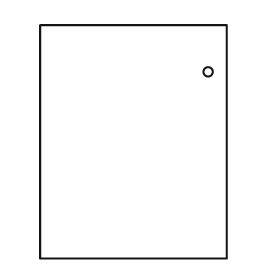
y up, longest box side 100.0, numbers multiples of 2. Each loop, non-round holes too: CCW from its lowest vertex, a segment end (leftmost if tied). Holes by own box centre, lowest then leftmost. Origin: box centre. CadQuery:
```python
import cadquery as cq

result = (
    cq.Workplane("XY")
    .moveTo(-40.0, -50.0)
    .lineTo(40.0, -50.0)
    .lineTo(40.0, 50.0)
    .lineTo(-40.0, 50.0)
    .close()
    .moveTo(32.0, 30.0)
    .circle(2.0)
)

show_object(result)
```